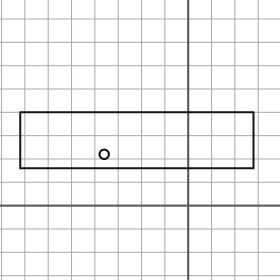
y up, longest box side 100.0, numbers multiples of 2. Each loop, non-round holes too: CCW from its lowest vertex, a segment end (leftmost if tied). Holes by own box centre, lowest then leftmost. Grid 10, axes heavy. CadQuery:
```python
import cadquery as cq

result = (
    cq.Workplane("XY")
    .moveTo(-72.0, 16.0)
    .lineTo(28.0, 16.0)
    .lineTo(28.0, 40.0)
    .lineTo(-72.0, 40.0)
    .close()
    .moveTo(-36.0, 22.0)
    .circle(2.0)
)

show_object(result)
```